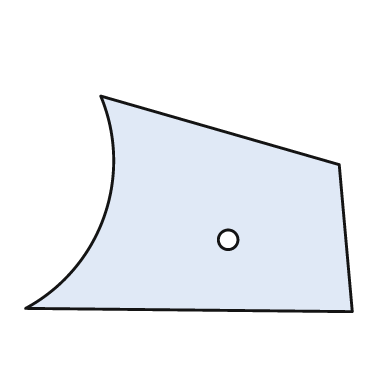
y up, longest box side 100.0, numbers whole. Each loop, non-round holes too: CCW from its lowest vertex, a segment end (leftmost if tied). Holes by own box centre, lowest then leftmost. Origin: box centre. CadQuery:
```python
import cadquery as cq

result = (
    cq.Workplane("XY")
    .moveTo(50.0, -33.0)
    .lineTo(46.0, 12.0)
    .lineTo(-27.0, 33.0)
    .threePointArc((-26.0, -4.0), (-50.0, -32.0))
    .close()
    .moveTo(12.0, -11.0)
    .circle(3.0)
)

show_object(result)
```